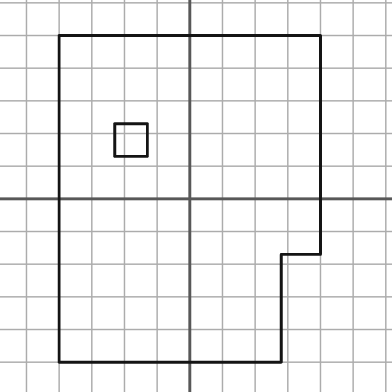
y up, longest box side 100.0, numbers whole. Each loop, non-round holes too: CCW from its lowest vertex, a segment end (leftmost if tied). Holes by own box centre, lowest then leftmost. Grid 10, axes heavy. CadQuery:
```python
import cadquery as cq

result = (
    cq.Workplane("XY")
    .moveTo(-40.0, -50.0)
    .lineTo(28.0, -50.0)
    .lineTo(28.0, -17.0)
    .lineTo(40.0, -17.0)
    .lineTo(40.0, 50.0)
    .lineTo(-40.0, 50.0)
    .close()
    .moveTo(-23.0, 13.0)
    .lineTo(-13.0, 13.0)
    .lineTo(-13.0, 23.0)
    .lineTo(-23.0, 23.0)
    .close()
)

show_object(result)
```